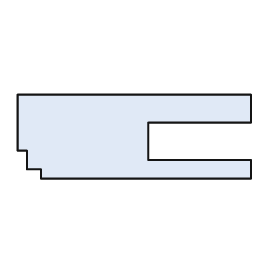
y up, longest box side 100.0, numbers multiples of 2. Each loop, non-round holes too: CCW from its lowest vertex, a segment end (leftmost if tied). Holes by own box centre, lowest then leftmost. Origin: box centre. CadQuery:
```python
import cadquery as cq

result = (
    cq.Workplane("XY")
    .moveTo(-40.0, -18.0)
    .lineTo(50.0, -18.0)
    .lineTo(50.0, -10.0)
    .lineTo(6.0, -10.0)
    .lineTo(6.0, 6.0)
    .lineTo(50.0, 6.0)
    .lineTo(50.0, 18.0)
    .lineTo(-50.0, 18.0)
    .lineTo(-50.0, -6.0)
    .lineTo(-46.0, -6.0)
    .lineTo(-46.0, -14.0)
    .lineTo(-40.0, -14.0)
    .close()
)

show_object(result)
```